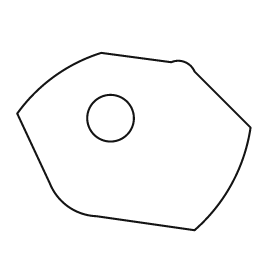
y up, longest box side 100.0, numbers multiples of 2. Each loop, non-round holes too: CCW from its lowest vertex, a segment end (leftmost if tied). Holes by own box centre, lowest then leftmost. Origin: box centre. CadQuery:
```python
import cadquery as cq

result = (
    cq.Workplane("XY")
    .moveTo(26.0, -38.0)
    .threePointArc((42.0, -18.0), (50.0, 6.0))
    .lineTo(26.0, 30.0)
    .threePointArc((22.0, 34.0), (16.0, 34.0))
    .lineTo(-14.0, 38.0)
    .threePointArc((-34.0, 28.0), (-50.0, 12.0))
    .lineTo(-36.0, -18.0)
    .threePointArc((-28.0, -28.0), (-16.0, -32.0))
    .close()
    .moveTo(-10.0, 10.0)
    .circle(10.0)
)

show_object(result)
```